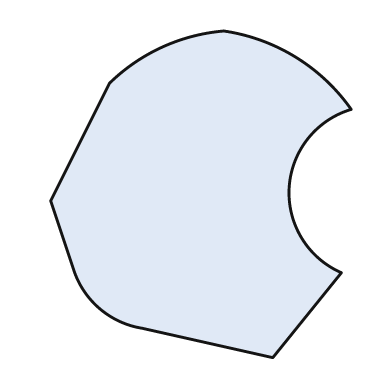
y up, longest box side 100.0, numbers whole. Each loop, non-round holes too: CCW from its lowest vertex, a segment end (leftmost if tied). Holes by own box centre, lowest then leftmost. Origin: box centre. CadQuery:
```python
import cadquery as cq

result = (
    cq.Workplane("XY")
    .moveTo(22.0, -50.0)
    .lineTo(43.0, -24.0)
    .threePointArc((27.0, 2.0), (46.0, 26.0))
    .threePointArc((29.0, 42.0), (7.0, 50.0))
    .threePointArc((-12.0, 45.0), (-28.0, 34.0))
    .lineTo(-46.0, -2.0)
    .lineTo(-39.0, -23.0)
    .threePointArc((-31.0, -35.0), (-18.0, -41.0))
    .close()
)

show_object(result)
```